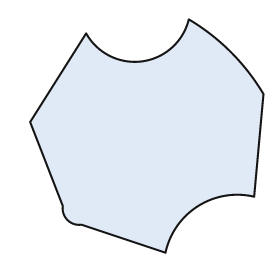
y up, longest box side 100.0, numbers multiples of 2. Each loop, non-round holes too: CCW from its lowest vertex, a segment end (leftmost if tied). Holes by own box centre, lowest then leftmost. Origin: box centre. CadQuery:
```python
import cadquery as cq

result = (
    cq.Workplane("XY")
    .moveTo(8.0, -50.0)
    .threePointArc((22.0, -30.0), (46.0, -26.0))
    .lineTo(50.0, 18.0)
    .threePointArc((36.0, 36.0), (18.0, 50.0))
    .threePointArc((-2.0, 32.0), (-26.0, 44.0))
    .lineTo(-50.0, 6.0)
    .lineTo(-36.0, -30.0)
    .threePointArc((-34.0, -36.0), (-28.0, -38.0))
    .close()
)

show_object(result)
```